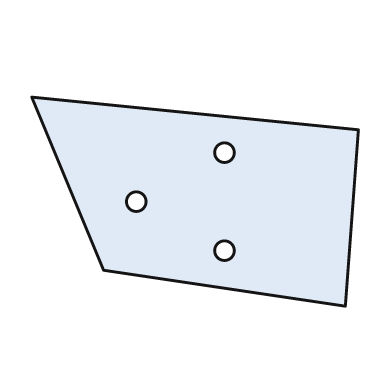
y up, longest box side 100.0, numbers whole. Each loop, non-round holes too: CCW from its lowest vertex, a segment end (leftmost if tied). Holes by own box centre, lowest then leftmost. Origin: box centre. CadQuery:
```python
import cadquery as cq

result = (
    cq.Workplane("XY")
    .moveTo(46.0, -32.0)
    .lineTo(50.0, 22.0)
    .lineTo(-50.0, 32.0)
    .lineTo(-28.0, -21.0)
    .close()
    .moveTo(9.0, -15.0)
    .circle(3.0)
    .moveTo(-18.0, 0.0)
    .circle(3.0)
    .moveTo(9.0, 15.0)
    .circle(3.0)
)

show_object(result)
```